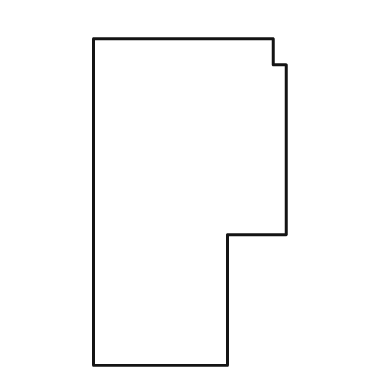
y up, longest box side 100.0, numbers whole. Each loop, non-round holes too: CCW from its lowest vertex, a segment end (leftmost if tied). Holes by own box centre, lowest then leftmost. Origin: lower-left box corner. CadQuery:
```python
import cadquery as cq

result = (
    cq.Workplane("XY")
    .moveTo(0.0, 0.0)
    .lineTo(41.0, 0.0)
    .lineTo(41.0, 40.0)
    .lineTo(59.0, 40.0)
    .lineTo(59.0, 92.0)
    .lineTo(55.0, 92.0)
    .lineTo(55.0, 100.0)
    .lineTo(0.0, 100.0)
    .close()
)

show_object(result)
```